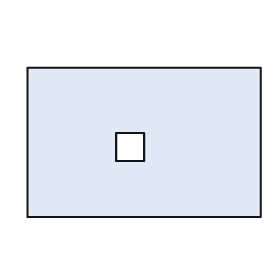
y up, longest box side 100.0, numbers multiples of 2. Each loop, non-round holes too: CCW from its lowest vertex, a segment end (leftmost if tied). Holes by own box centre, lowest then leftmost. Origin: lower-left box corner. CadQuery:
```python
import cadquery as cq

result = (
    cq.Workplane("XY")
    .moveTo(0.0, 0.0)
    .lineTo(100.0, 0.0)
    .lineTo(100.0, 64.0)
    .lineTo(0.0, 64.0)
    .close()
    .moveTo(38.0, 24.0)
    .lineTo(50.0, 24.0)
    .lineTo(50.0, 36.0)
    .lineTo(38.0, 36.0)
    .close()
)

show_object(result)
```